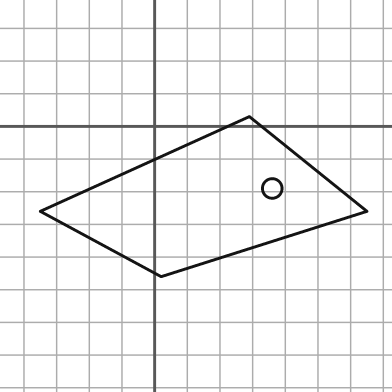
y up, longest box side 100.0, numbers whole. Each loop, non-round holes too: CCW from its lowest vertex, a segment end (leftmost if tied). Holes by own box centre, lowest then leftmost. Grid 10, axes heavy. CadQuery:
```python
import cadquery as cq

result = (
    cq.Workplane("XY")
    .moveTo(2.0, -46.0)
    .lineTo(65.0, -26.0)
    .lineTo(29.0, 3.0)
    .lineTo(-35.0, -26.0)
    .close()
    .moveTo(36.0, -19.0)
    .circle(3.0)
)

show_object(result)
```